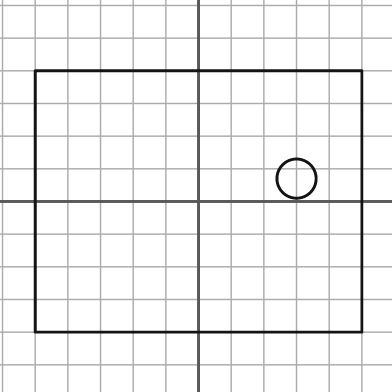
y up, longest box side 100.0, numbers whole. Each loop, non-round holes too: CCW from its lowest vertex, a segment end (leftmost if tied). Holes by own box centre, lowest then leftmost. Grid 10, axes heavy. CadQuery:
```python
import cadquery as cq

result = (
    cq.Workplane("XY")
    .moveTo(-50.0, -40.0)
    .lineTo(50.0, -40.0)
    .lineTo(50.0, 40.0)
    .lineTo(-50.0, 40.0)
    .close()
    .moveTo(30.0, 7.0)
    .circle(6.0)
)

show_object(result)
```